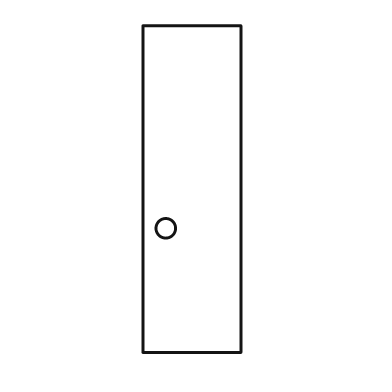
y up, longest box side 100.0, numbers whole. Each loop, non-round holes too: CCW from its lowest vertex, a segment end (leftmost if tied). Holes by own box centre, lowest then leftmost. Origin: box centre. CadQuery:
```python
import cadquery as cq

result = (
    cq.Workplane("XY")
    .moveTo(-15.0, -50.0)
    .lineTo(15.0, -50.0)
    .lineTo(15.0, 50.0)
    .lineTo(-15.0, 50.0)
    .close()
    .moveTo(-8.0, -12.0)
    .circle(3.0)
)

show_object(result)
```